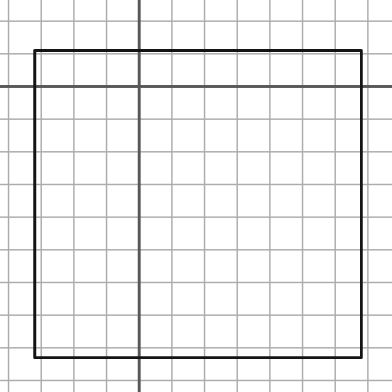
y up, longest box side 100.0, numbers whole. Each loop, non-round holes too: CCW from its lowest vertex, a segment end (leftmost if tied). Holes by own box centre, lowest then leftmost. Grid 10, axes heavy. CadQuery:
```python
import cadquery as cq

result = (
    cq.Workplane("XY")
    .moveTo(-32.0, -83.0)
    .lineTo(68.0, -83.0)
    .lineTo(68.0, 11.0)
    .lineTo(-32.0, 11.0)
    .close()
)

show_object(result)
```